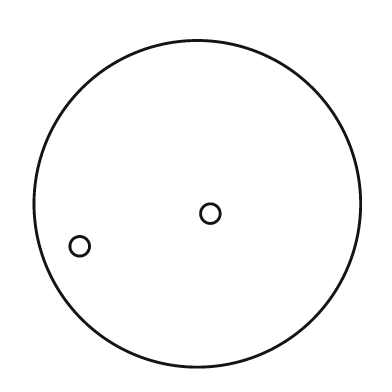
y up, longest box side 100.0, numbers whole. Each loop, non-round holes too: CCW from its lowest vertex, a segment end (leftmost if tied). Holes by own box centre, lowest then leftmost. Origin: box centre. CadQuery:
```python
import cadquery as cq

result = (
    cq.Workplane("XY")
    .moveTo(0.0, 0.0)
    .circle(50.0)
    .moveTo(-36.0, -13.0)
    .circle(3.0)
    .moveTo(4.0, -3.0)
    .circle(3.0)
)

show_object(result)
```